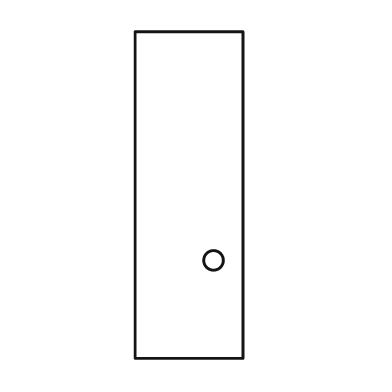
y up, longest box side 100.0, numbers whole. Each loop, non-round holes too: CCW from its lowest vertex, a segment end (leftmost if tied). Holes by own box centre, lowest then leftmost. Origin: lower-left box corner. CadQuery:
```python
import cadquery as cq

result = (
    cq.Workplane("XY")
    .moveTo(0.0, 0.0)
    .lineTo(33.0, 0.0)
    .lineTo(33.0, 100.0)
    .lineTo(0.0, 100.0)
    .close()
    .moveTo(24.0, 30.0)
    .circle(3.0)
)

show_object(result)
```